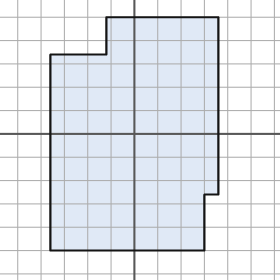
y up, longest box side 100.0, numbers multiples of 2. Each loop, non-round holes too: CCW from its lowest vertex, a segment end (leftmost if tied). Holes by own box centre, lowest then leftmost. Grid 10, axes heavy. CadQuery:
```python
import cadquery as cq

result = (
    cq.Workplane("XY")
    .moveTo(-36.0, -50.0)
    .lineTo(30.0, -50.0)
    .lineTo(30.0, -26.0)
    .lineTo(36.0, -26.0)
    .lineTo(36.0, 50.0)
    .lineTo(-12.0, 50.0)
    .lineTo(-12.0, 34.0)
    .lineTo(-36.0, 34.0)
    .close()
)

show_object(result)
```